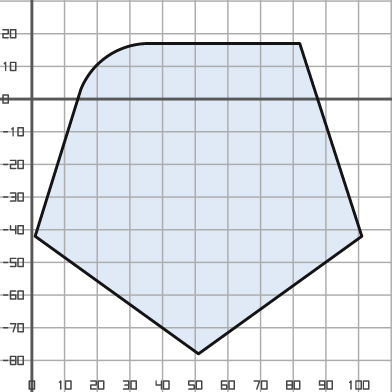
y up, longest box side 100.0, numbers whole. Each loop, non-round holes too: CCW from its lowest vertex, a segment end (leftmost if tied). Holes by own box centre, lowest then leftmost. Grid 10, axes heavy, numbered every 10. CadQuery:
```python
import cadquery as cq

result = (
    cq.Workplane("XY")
    .moveTo(51.0, -78.0)
    .lineTo(101.0, -42.0)
    .lineTo(82.0, 17.0)
    .lineTo(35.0, 17.0)
    .threePointArc((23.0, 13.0), (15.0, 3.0))
    .lineTo(1.0, -42.0)
    .close()
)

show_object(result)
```